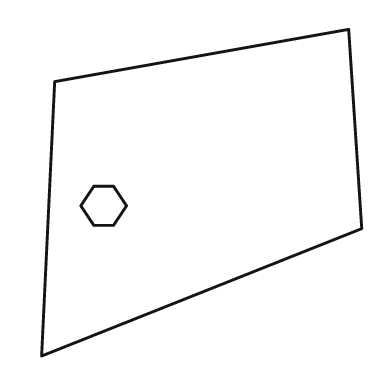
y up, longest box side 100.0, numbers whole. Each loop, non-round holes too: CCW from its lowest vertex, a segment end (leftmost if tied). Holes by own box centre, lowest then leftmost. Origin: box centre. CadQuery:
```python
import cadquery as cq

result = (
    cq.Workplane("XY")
    .moveTo(-49.0, -50.0)
    .lineTo(49.0, -11.0)
    .lineTo(45.0, 50.0)
    .lineTo(-45.0, 34.0)
    .close()
    .moveTo(-33.0, -10.0)
    .lineTo(-27.0, -10.0)
    .lineTo(-23.0, -4.0)
    .lineTo(-27.0, 2.0)
    .lineTo(-33.0, 2.0)
    .lineTo(-37.0, -4.0)
    .close()
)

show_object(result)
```